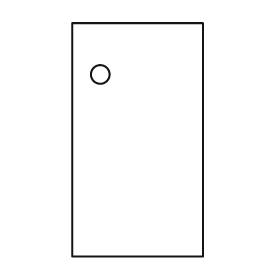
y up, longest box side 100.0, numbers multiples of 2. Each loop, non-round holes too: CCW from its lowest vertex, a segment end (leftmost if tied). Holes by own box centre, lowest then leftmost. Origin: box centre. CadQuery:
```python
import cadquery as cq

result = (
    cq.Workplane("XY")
    .moveTo(-28.0, -50.0)
    .lineTo(28.0, -50.0)
    .lineTo(28.0, 50.0)
    .lineTo(-28.0, 50.0)
    .close()
    .moveTo(-16.0, 28.0)
    .circle(4.0)
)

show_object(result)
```